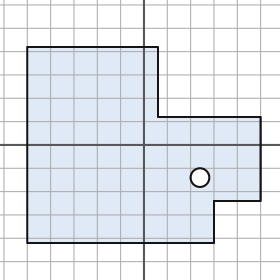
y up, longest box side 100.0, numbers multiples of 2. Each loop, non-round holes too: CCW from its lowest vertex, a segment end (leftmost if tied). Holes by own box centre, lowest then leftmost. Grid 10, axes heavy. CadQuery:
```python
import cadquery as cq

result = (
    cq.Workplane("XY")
    .moveTo(-50.0, -42.0)
    .lineTo(30.0, -42.0)
    .lineTo(30.0, -24.0)
    .lineTo(50.0, -24.0)
    .lineTo(50.0, 12.0)
    .lineTo(6.0, 12.0)
    .lineTo(6.0, 42.0)
    .lineTo(-50.0, 42.0)
    .close()
    .moveTo(24.0, -14.0)
    .circle(4.0)
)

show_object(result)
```